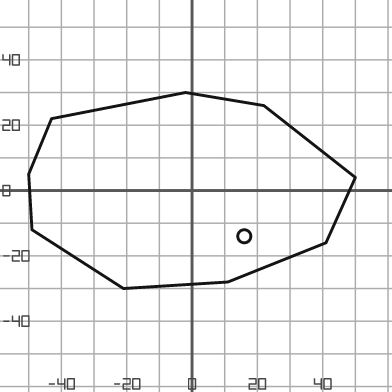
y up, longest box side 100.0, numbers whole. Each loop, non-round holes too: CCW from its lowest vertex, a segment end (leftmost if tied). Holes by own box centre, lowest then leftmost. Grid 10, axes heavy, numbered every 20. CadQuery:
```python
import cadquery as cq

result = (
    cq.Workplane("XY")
    .moveTo(-21.0, -30.0)
    .lineTo(11.0, -28.0)
    .lineTo(41.0, -16.0)
    .lineTo(50.0, 4.0)
    .lineTo(22.0, 26.0)
    .lineTo(-2.0, 30.0)
    .lineTo(-43.0, 22.0)
    .lineTo(-50.0, 5.0)
    .lineTo(-49.0, -12.0)
    .close()
    .moveTo(16.0, -14.0)
    .circle(2.0)
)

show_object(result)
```